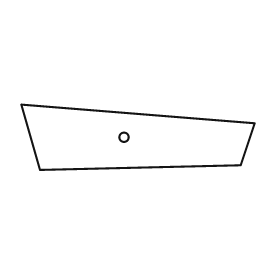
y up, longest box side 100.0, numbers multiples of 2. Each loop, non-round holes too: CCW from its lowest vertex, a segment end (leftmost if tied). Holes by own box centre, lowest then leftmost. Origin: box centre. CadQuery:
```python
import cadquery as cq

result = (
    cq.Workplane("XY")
    .moveTo(-42.0, -14.0)
    .lineTo(44.0, -12.0)
    .lineTo(50.0, 6.0)
    .lineTo(-50.0, 14.0)
    .close()
    .moveTo(-6.0, 0.0)
    .circle(2.0)
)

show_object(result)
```